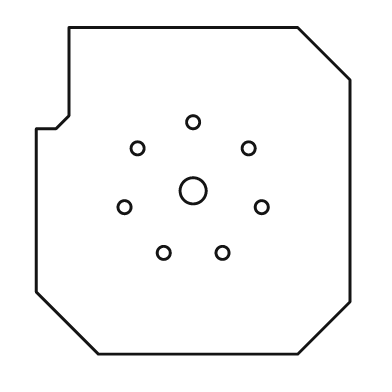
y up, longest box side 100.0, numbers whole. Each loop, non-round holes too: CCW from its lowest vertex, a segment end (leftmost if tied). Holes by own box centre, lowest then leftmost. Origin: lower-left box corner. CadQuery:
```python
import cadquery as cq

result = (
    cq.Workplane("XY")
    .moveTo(19.0, 0.0)
    .lineTo(80.0, 0.0)
    .lineTo(96.0, 16.0)
    .lineTo(96.0, 84.0)
    .lineTo(80.0, 100.0)
    .lineTo(10.0, 100.0)
    .lineTo(10.0, 73.0)
    .lineTo(6.0, 69.0)
    .lineTo(0.0, 69.0)
    .lineTo(0.0, 19.0)
    .close()
    .moveTo(39.0, 31.0)
    .circle(2.0)
    .moveTo(57.0, 31.0)
    .circle(2.0)
    .moveTo(27.0, 45.0)
    .circle(2.0)
    .moveTo(69.0, 45.0)
    .circle(2.0)
    .moveTo(48.0, 50.0)
    .circle(4.0)
    .moveTo(31.0, 63.0)
    .circle(2.0)
    .moveTo(65.0, 63.0)
    .circle(2.0)
    .moveTo(48.0, 71.0)
    .circle(2.0)
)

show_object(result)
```